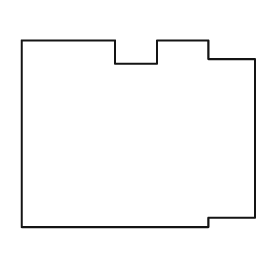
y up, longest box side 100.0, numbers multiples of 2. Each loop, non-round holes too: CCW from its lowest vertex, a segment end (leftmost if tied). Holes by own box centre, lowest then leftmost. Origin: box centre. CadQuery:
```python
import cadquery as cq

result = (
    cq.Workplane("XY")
    .moveTo(-50.0, -40.0)
    .lineTo(30.0, -40.0)
    .lineTo(30.0, -36.0)
    .lineTo(50.0, -36.0)
    .lineTo(50.0, 32.0)
    .lineTo(30.0, 32.0)
    .lineTo(30.0, 40.0)
    .lineTo(8.0, 40.0)
    .lineTo(8.0, 30.0)
    .lineTo(-10.0, 30.0)
    .lineTo(-10.0, 40.0)
    .lineTo(-50.0, 40.0)
    .close()
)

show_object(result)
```